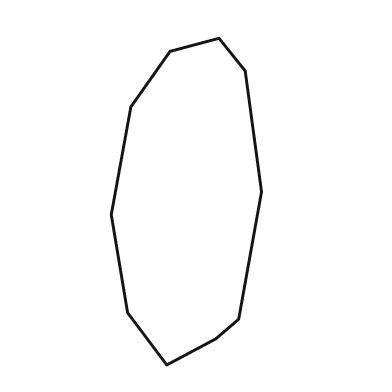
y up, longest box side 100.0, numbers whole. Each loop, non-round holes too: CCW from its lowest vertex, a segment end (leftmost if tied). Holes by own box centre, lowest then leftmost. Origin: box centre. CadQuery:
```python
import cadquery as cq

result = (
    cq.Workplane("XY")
    .moveTo(-6.0, -50.0)
    .lineTo(9.0, -42.0)
    .lineTo(16.0, -36.0)
    .lineTo(23.0, 3.0)
    .lineTo(18.0, 40.0)
    .lineTo(10.0, 50.0)
    .lineTo(-5.0, 46.0)
    .lineTo(-17.0, 29.0)
    .lineTo(-23.0, -4.0)
    .lineTo(-18.0, -34.0)
    .close()
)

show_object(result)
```